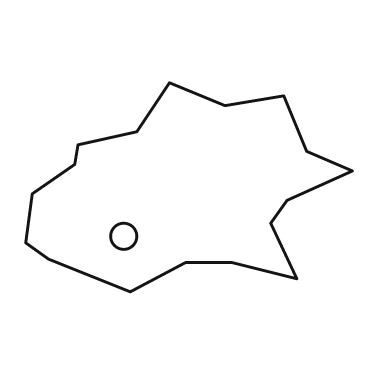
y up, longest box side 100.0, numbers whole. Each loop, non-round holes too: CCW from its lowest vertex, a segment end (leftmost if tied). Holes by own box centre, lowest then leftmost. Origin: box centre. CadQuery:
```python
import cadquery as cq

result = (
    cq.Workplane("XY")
    .moveTo(-18.0, -32.0)
    .lineTo(-1.0, -23.0)
    .lineTo(13.0, -23.0)
    .lineTo(33.0, -28.0)
    .lineTo(25.0, -11.0)
    .lineTo(30.0, -4.0)
    .lineTo(50.0, 5.0)
    .lineTo(36.0, 11.0)
    .lineTo(29.0, 28.0)
    .lineTo(11.0, 25.0)
    .lineTo(-6.0, 32.0)
    .lineTo(-16.0, 17.0)
    .lineTo(-34.0, 13.0)
    .lineTo(-35.0, 7.0)
    .lineTo(-48.0, -2.0)
    .lineTo(-50.0, -17.0)
    .lineTo(-43.0, -22.0)
    .close()
    .moveTo(-20.0, -15.0)
    .circle(4.0)
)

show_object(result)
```